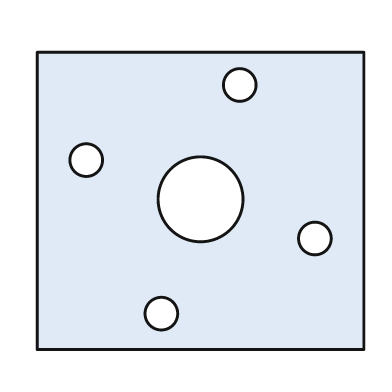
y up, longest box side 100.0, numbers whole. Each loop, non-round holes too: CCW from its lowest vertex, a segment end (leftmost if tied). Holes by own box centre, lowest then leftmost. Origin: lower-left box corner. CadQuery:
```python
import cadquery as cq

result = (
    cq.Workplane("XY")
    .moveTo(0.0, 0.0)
    .lineTo(100.0, 0.0)
    .lineTo(100.0, 91.0)
    .lineTo(0.0, 91.0)
    .close()
    .moveTo(38.0, 11.0)
    .circle(5.0)
    .moveTo(85.0, 34.0)
    .circle(5.0)
    .moveTo(50.0, 46.0)
    .circle(13.0)
    .moveTo(15.0, 58.0)
    .circle(5.0)
    .moveTo(62.0, 81.0)
    .circle(5.0)
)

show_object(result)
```